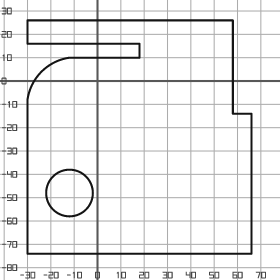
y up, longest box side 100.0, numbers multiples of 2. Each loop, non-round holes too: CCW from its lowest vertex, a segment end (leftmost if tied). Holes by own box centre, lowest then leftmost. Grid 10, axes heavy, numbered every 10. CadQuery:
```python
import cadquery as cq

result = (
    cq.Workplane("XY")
    .moveTo(-30.0, -74.0)
    .lineTo(66.0, -74.0)
    .lineTo(66.0, -14.0)
    .lineTo(58.0, -14.0)
    .lineTo(58.0, 26.0)
    .lineTo(-30.0, 26.0)
    .lineTo(-30.0, 16.0)
    .lineTo(18.0, 16.0)
    .lineTo(18.0, 10.0)
    .lineTo(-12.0, 10.0)
    .threePointArc((-24.0, 4.0), (-30.0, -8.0))
    .close()
    .moveTo(-12.0, -48.0)
    .circle(10.0)
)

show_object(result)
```